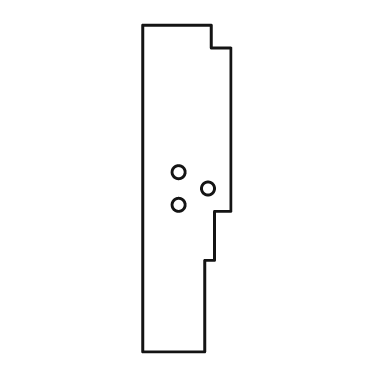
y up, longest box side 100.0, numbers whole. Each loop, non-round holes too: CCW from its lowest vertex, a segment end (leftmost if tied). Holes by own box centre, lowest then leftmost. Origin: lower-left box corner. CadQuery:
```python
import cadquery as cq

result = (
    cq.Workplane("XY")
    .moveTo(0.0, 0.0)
    .lineTo(19.0, 0.0)
    .lineTo(19.0, 28.0)
    .lineTo(22.0, 28.0)
    .lineTo(22.0, 43.0)
    .lineTo(27.0, 43.0)
    .lineTo(27.0, 93.0)
    .lineTo(21.0, 93.0)
    .lineTo(21.0, 100.0)
    .lineTo(0.0, 100.0)
    .close()
    .moveTo(11.0, 45.0)
    .circle(2.0)
    .moveTo(20.0, 50.0)
    .circle(2.0)
    .moveTo(11.0, 55.0)
    .circle(2.0)
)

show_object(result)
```